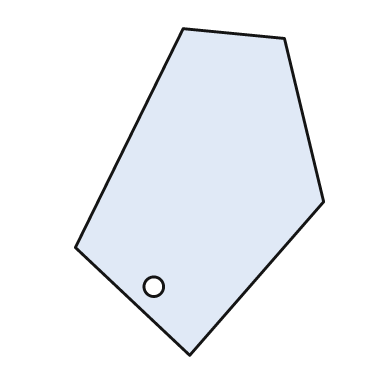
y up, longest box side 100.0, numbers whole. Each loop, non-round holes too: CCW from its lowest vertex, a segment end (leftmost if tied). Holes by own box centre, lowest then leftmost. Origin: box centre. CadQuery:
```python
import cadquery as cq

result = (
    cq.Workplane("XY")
    .moveTo(-3.0, -50.0)
    .lineTo(38.0, -3.0)
    .lineTo(26.0, 47.0)
    .lineTo(-5.0, 50.0)
    .lineTo(-38.0, -17.0)
    .close()
    .moveTo(-14.0, -29.0)
    .circle(3.0)
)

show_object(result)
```